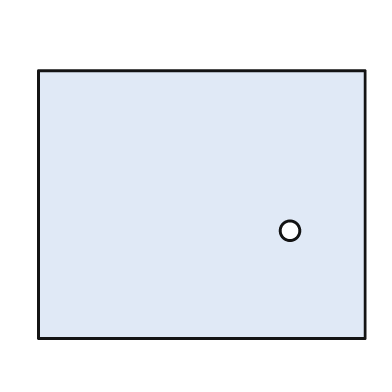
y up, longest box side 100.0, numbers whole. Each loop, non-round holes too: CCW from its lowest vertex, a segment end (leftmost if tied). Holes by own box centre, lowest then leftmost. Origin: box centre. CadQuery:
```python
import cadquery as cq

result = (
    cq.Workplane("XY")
    .moveTo(-50.0, -41.0)
    .lineTo(50.0, -41.0)
    .lineTo(50.0, 41.0)
    .lineTo(-50.0, 41.0)
    .close()
    .moveTo(27.0, -8.0)
    .circle(3.0)
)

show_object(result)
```